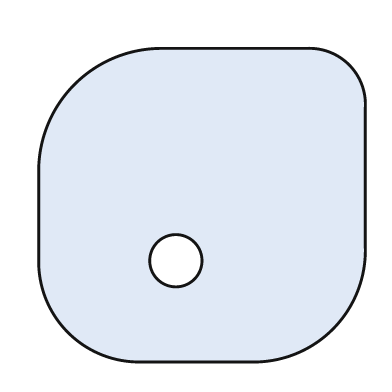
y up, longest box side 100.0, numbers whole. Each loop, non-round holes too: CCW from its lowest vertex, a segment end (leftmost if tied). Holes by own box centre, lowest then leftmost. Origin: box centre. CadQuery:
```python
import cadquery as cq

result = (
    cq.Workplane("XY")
    .moveTo(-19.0, -48.0)
    .lineTo(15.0, -48.0)
    .threePointArc((40.0, -38.0), (50.0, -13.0))
    .lineTo(50.0, 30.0)
    .threePointArc((45.0, 43.0), (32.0, 48.0))
    .lineTo(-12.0, 48.0)
    .threePointArc((-39.0, 37.0), (-50.0, 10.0))
    .lineTo(-50.0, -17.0)
    .threePointArc((-41.0, -39.0), (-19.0, -48.0))
    .close()
    .moveTo(-8.0, -17.0)
    .circle(8.0)
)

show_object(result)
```